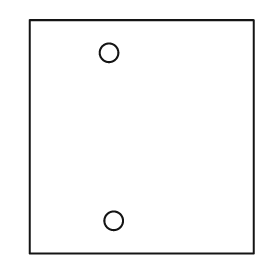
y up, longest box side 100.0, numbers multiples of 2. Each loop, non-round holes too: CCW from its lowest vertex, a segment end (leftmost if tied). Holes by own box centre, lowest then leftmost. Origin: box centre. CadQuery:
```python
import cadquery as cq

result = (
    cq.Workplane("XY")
    .moveTo(-48.0, -50.0)
    .lineTo(48.0, -50.0)
    .lineTo(48.0, 50.0)
    .lineTo(-48.0, 50.0)
    .close()
    .moveTo(-12.0, -36.0)
    .circle(4.0)
    .moveTo(-14.0, 36.0)
    .circle(4.0)
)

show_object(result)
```